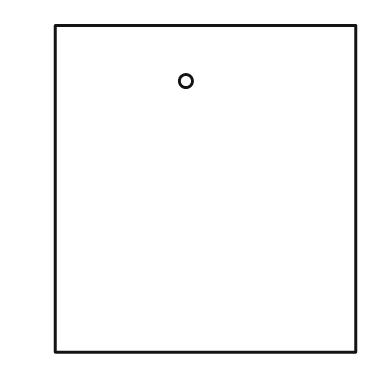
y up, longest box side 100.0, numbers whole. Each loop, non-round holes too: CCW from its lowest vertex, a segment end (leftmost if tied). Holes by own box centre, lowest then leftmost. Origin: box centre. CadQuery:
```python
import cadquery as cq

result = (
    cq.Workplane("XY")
    .moveTo(-46.0, -50.0)
    .lineTo(46.0, -50.0)
    .lineTo(46.0, 50.0)
    .lineTo(-46.0, 50.0)
    .close()
    .moveTo(-6.0, 33.0)
    .circle(2.0)
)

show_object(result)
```